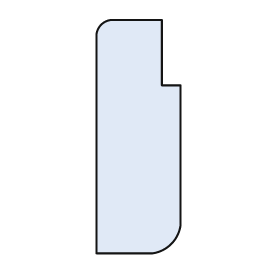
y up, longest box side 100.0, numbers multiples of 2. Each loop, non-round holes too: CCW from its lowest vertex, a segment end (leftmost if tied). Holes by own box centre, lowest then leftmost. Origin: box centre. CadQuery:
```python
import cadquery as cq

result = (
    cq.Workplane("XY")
    .moveTo(-18.0, -50.0)
    .lineTo(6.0, -50.0)
    .threePointArc((14.0, -46.0), (18.0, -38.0))
    .lineTo(18.0, 22.0)
    .lineTo(10.0, 22.0)
    .lineTo(10.0, 50.0)
    .lineTo(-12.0, 50.0)
    .threePointArc((-16.0, 48.0), (-18.0, 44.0))
    .close()
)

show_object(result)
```